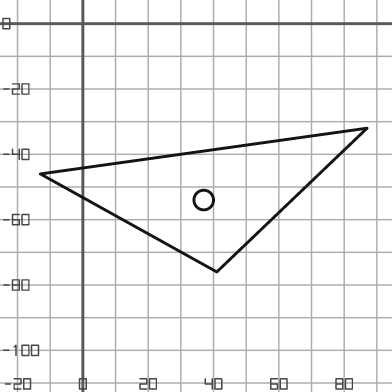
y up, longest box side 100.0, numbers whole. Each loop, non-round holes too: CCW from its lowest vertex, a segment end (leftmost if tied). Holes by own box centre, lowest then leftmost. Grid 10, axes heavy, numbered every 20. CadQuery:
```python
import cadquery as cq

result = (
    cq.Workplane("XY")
    .moveTo(41.0, -76.0)
    .lineTo(87.0, -32.0)
    .lineTo(-13.0, -46.0)
    .close()
    .moveTo(37.0, -54.0)
    .circle(3.0)
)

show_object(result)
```